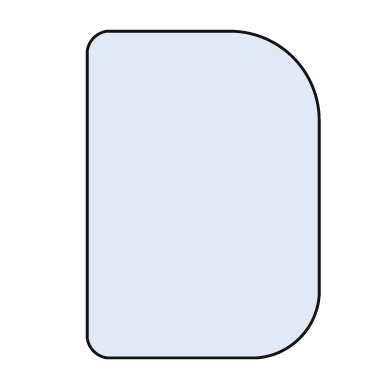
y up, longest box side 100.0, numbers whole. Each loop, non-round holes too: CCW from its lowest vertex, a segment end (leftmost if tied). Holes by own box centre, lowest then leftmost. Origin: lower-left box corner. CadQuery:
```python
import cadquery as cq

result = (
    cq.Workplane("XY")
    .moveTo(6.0, 0.0)
    .lineTo(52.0, 0.0)
    .threePointArc((65.0, 6.0), (71.0, 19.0))
    .lineTo(71.0, 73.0)
    .threePointArc((63.0, 92.0), (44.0, 100.0))
    .lineTo(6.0, 100.0)
    .threePointArc((2.0, 98.0), (0.0, 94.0))
    .lineTo(0.0, 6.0)
    .threePointArc((2.0, 2.0), (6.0, 0.0))
    .close()
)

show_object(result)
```